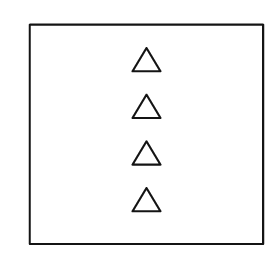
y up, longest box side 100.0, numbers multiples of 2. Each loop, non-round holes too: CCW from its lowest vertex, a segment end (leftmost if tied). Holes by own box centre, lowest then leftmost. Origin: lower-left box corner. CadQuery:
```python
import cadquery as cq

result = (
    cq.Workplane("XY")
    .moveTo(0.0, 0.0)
    .lineTo(100.0, 0.0)
    .lineTo(100.0, 94.0)
    .lineTo(0.0, 94.0)
    .close()
    .moveTo(44.0, 14.0)
    .lineTo(56.0, 14.0)
    .lineTo(50.0, 24.0)
    .close()
    .moveTo(44.0, 34.0)
    .lineTo(56.0, 34.0)
    .lineTo(50.0, 44.0)
    .close()
    .moveTo(44.0, 54.0)
    .lineTo(56.0, 54.0)
    .lineTo(50.0, 64.0)
    .close()
    .moveTo(44.0, 74.0)
    .lineTo(56.0, 74.0)
    .lineTo(50.0, 84.0)
    .close()
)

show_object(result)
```